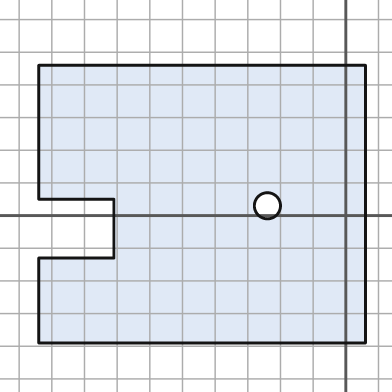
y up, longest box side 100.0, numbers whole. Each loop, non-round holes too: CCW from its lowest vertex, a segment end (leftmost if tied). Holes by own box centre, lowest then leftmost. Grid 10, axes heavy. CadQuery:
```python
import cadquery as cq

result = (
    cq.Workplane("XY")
    .moveTo(-94.0, -39.0)
    .lineTo(6.0, -39.0)
    .lineTo(6.0, 46.0)
    .lineTo(-94.0, 46.0)
    .lineTo(-94.0, 5.0)
    .lineTo(-71.0, 5.0)
    .lineTo(-71.0, -13.0)
    .lineTo(-94.0, -13.0)
    .close()
    .moveTo(-24.0, 3.0)
    .circle(4.0)
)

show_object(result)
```